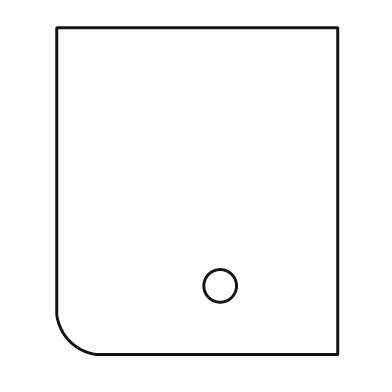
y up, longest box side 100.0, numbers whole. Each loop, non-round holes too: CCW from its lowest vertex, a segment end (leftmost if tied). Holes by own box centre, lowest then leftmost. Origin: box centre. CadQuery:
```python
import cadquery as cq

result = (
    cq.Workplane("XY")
    .moveTo(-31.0, -50.0)
    .lineTo(43.0, -50.0)
    .lineTo(43.0, 50.0)
    .lineTo(-43.0, 50.0)
    .lineTo(-43.0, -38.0)
    .threePointArc((-39.0, -46.0), (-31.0, -50.0))
    .close()
    .moveTo(7.0, -29.0)
    .circle(5.0)
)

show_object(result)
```